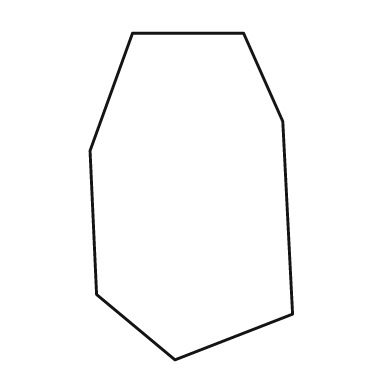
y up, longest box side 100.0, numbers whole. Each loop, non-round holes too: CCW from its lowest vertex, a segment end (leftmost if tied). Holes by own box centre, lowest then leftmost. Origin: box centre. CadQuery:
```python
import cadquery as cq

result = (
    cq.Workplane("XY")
    .moveTo(-5.0, -50.0)
    .lineTo(31.0, -36.0)
    .lineTo(28.0, 23.0)
    .lineTo(16.0, 50.0)
    .lineTo(-18.0, 50.0)
    .lineTo(-31.0, 14.0)
    .lineTo(-29.0, -30.0)
    .close()
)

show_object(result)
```